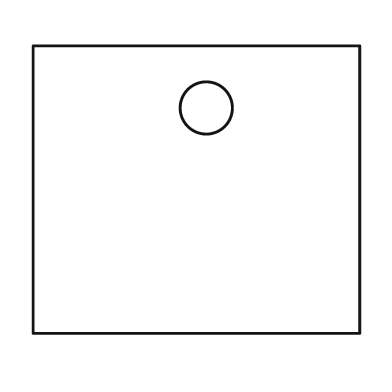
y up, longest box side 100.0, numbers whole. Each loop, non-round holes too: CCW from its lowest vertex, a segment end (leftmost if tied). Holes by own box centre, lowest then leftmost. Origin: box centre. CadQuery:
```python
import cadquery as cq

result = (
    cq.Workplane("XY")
    .moveTo(-50.0, -44.0)
    .lineTo(50.0, -44.0)
    .lineTo(50.0, 44.0)
    .lineTo(-50.0, 44.0)
    .close()
    .moveTo(3.0, 25.0)
    .circle(8.0)
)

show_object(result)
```